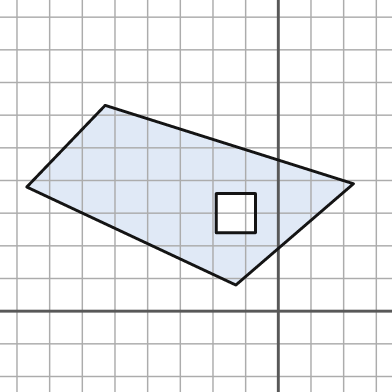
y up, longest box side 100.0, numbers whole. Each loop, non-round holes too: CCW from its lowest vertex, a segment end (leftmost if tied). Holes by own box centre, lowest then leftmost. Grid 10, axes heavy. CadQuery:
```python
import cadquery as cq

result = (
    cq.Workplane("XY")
    .moveTo(-13.0, 8.0)
    .lineTo(23.0, 39.0)
    .lineTo(-53.0, 63.0)
    .lineTo(-77.0, 38.0)
    .close()
    .moveTo(-19.0, 24.0)
    .lineTo(-7.0, 24.0)
    .lineTo(-7.0, 36.0)
    .lineTo(-19.0, 36.0)
    .close()
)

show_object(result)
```